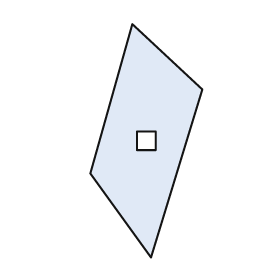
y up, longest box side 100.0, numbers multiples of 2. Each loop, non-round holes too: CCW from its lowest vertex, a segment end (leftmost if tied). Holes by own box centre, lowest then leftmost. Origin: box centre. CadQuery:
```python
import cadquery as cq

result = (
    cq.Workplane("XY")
    .moveTo(2.0, -50.0)
    .lineTo(24.0, 22.0)
    .lineTo(-6.0, 50.0)
    .lineTo(-24.0, -14.0)
    .close()
    .moveTo(-4.0, -4.0)
    .lineTo(4.0, -4.0)
    .lineTo(4.0, 4.0)
    .lineTo(-4.0, 4.0)
    .close()
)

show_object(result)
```